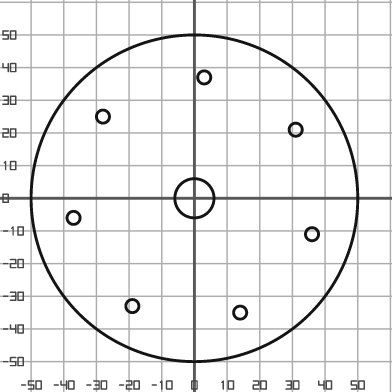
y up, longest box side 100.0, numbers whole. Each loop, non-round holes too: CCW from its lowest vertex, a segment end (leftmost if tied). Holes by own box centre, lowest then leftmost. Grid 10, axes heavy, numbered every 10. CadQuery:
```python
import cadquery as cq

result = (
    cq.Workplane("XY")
    .moveTo(0.0, 0.0)
    .circle(50.0)
    .moveTo(14.0, -35.0)
    .circle(2.0)
    .moveTo(-19.0, -33.0)
    .circle(2.0)
    .moveTo(36.0, -11.0)
    .circle(2.0)
    .moveTo(-37.0, -6.0)
    .circle(2.0)
    .moveTo(0.0, 0.0)
    .circle(6.0)
    .moveTo(31.0, 21.0)
    .circle(2.0)
    .moveTo(-28.0, 25.0)
    .circle(2.0)
    .moveTo(3.0, 37.0)
    .circle(2.0)
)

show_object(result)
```